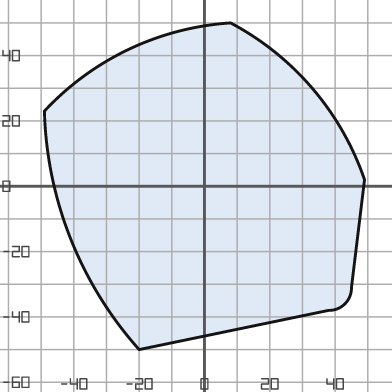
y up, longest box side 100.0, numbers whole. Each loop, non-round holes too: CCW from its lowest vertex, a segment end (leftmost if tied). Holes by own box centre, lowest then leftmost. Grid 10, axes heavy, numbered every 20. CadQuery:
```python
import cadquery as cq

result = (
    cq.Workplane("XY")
    .moveTo(-20.0, -50.0)
    .lineTo(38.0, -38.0)
    .threePointArc((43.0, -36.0), (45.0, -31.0))
    .lineTo(49.0, 2.0)
    .threePointArc((33.0, 30.0), (8.0, 50.0))
    .threePointArc((-23.0, 42.0), (-49.0, 23.0))
    .threePointArc((-41.0, -16.0), (-20.0, -50.0))
    .close()
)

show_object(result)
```